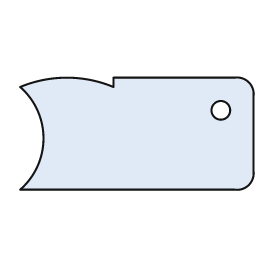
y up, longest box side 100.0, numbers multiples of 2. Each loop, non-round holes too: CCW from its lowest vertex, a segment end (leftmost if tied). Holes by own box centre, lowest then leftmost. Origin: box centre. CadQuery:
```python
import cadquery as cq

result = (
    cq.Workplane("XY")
    .moveTo(-50.0, -24.0)
    .lineTo(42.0, -24.0)
    .threePointArc((48.0, -22.0), (50.0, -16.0))
    .lineTo(50.0, 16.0)
    .threePointArc((48.0, 22.0), (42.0, 24.0))
    .lineTo(-10.0, 24.0)
    .lineTo(-10.0, 20.0)
    .threePointArc((-30.0, 24.0), (-50.0, 20.0))
    .threePointArc((-40.0, -2.0), (-50.0, -24.0))
    .close()
    .moveTo(36.0, 10.0)
    .circle(4.0)
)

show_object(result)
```